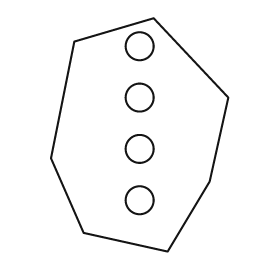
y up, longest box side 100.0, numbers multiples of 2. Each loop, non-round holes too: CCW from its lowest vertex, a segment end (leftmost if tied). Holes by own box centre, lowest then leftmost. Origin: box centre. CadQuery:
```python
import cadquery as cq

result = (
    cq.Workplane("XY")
    .moveTo(12.0, -50.0)
    .lineTo(30.0, -20.0)
    .lineTo(38.0, 16.0)
    .lineTo(6.0, 50.0)
    .lineTo(-28.0, 40.0)
    .lineTo(-38.0, -10.0)
    .lineTo(-24.0, -42.0)
    .close()
    .moveTo(0.0, -28.0)
    .circle(6.0)
    .moveTo(0.0, -6.0)
    .circle(6.0)
    .moveTo(0.0, 16.0)
    .circle(6.0)
    .moveTo(0.0, 38.0)
    .circle(6.0)
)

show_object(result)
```